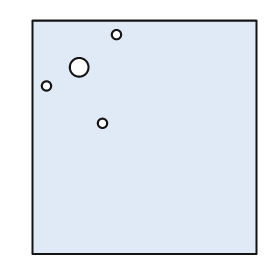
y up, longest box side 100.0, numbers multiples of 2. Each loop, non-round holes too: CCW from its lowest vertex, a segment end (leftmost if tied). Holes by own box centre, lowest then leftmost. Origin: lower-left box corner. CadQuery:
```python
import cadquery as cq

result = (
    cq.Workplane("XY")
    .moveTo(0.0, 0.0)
    .lineTo(96.0, 0.0)
    .lineTo(96.0, 100.0)
    .lineTo(0.0, 100.0)
    .close()
    .moveTo(30.0, 56.0)
    .circle(2.0)
    .moveTo(6.0, 72.0)
    .circle(2.0)
    .moveTo(20.0, 80.0)
    .circle(4.0)
    .moveTo(36.0, 94.0)
    .circle(2.0)
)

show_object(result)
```